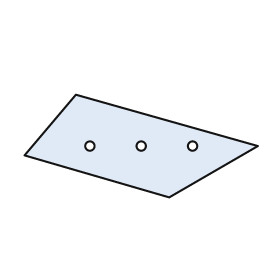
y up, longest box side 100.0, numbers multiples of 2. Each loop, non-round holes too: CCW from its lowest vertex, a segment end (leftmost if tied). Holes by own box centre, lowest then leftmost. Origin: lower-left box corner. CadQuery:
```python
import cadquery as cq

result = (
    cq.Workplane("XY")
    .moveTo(62.0, 0.0)
    .lineTo(100.0, 22.0)
    .lineTo(22.0, 44.0)
    .lineTo(0.0, 18.0)
    .close()
    .moveTo(28.0, 22.0)
    .circle(2.0)
    .moveTo(50.0, 22.0)
    .circle(2.0)
    .moveTo(72.0, 22.0)
    .circle(2.0)
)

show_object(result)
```